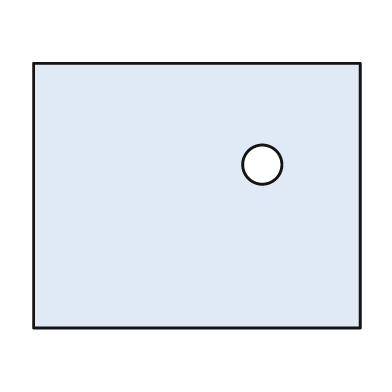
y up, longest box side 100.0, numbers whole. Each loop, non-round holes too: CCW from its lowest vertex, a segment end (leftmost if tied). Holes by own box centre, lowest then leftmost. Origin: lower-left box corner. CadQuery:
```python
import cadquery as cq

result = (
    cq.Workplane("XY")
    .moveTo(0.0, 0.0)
    .lineTo(100.0, 0.0)
    .lineTo(100.0, 81.0)
    .lineTo(0.0, 81.0)
    .close()
    .moveTo(70.0, 50.0)
    .circle(6.0)
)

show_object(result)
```